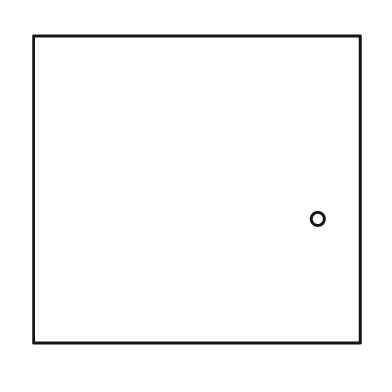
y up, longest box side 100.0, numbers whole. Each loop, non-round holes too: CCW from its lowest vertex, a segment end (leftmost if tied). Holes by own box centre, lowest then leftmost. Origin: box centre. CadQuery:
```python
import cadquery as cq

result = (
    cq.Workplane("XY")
    .moveTo(-50.0, -47.0)
    .lineTo(50.0, -47.0)
    .lineTo(50.0, 47.0)
    .lineTo(-50.0, 47.0)
    .close()
    .moveTo(37.0, -9.0)
    .circle(2.0)
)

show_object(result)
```